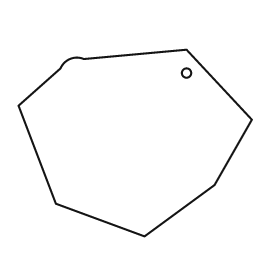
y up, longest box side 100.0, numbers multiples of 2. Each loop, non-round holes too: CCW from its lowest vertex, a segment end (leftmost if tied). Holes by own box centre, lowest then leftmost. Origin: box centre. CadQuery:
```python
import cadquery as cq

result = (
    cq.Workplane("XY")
    .moveTo(4.0, -40.0)
    .lineTo(34.0, -18.0)
    .lineTo(50.0, 10.0)
    .lineTo(22.0, 40.0)
    .lineTo(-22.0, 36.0)
    .threePointArc((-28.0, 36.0), (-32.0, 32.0))
    .lineTo(-50.0, 16.0)
    .lineTo(-34.0, -26.0)
    .close()
    .moveTo(22.0, 30.0)
    .circle(2.0)
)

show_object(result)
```